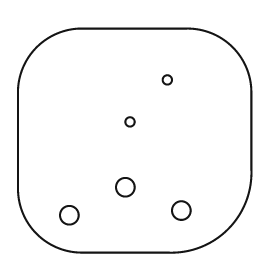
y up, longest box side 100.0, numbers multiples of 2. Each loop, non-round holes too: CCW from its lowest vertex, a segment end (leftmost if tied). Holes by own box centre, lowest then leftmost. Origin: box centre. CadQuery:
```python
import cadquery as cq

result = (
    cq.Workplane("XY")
    .moveTo(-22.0, -48.0)
    .lineTo(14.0, -48.0)
    .threePointArc((40.0, -38.0), (50.0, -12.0))
    .lineTo(50.0, 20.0)
    .threePointArc((42.0, 40.0), (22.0, 48.0))
    .lineTo(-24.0, 48.0)
    .threePointArc((-42.0, 40.0), (-50.0, 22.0))
    .lineTo(-50.0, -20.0)
    .threePointArc((-42.0, -40.0), (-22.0, -48.0))
    .close()
    .moveTo(-28.0, -32.0)
    .circle(4.0)
    .moveTo(20.0, -30.0)
    .circle(4.0)
    .moveTo(-4.0, -20.0)
    .circle(4.0)
    .moveTo(-2.0, 8.0)
    .circle(2.0)
    .moveTo(14.0, 26.0)
    .circle(2.0)
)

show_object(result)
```